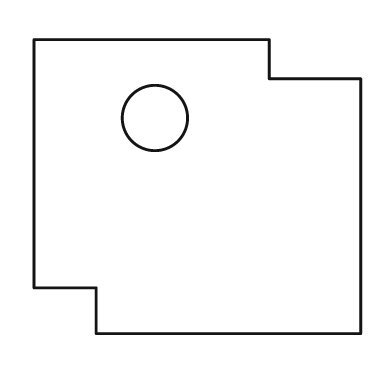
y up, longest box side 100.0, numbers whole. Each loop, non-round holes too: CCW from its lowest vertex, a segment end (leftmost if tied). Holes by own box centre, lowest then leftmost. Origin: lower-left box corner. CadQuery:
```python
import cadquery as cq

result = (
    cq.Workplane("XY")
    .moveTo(19.0, 0.0)
    .lineTo(100.0, 0.0)
    .lineTo(100.0, 78.0)
    .lineTo(72.0, 78.0)
    .lineTo(72.0, 90.0)
    .lineTo(0.0, 90.0)
    .lineTo(0.0, 14.0)
    .lineTo(19.0, 14.0)
    .close()
    .moveTo(37.0, 66.0)
    .circle(10.0)
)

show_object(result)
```